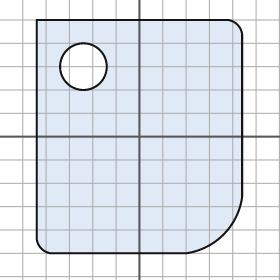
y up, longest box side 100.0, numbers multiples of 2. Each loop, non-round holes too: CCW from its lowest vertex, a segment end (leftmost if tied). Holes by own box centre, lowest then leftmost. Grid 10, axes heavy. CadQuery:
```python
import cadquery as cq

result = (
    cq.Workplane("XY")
    .moveTo(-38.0, -50.0)
    .lineTo(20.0, -50.0)
    .threePointArc((36.0, -42.0), (44.0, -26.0))
    .lineTo(44.0, 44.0)
    .threePointArc((42.0, 48.0), (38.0, 50.0))
    .lineTo(-44.0, 50.0)
    .lineTo(-44.0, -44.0)
    .threePointArc((-42.0, -48.0), (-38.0, -50.0))
    .close()
    .moveTo(-24.0, 30.0)
    .circle(10.0)
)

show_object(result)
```